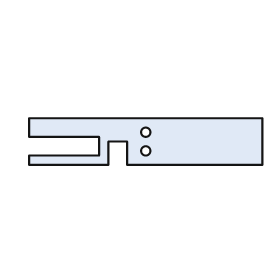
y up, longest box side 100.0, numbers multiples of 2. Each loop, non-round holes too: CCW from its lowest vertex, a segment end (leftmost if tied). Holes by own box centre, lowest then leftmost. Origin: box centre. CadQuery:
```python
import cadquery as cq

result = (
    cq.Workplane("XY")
    .moveTo(-50.0, -10.0)
    .lineTo(-16.0, -10.0)
    .lineTo(-16.0, 0.0)
    .lineTo(-8.0, 0.0)
    .lineTo(-8.0, -10.0)
    .lineTo(50.0, -10.0)
    .lineTo(50.0, 10.0)
    .lineTo(-50.0, 10.0)
    .lineTo(-50.0, 2.0)
    .lineTo(-20.0, 2.0)
    .lineTo(-20.0, -6.0)
    .lineTo(-50.0, -6.0)
    .close()
    .moveTo(0.0, -4.0)
    .circle(2.0)
    .moveTo(0.0, 4.0)
    .circle(2.0)
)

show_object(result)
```